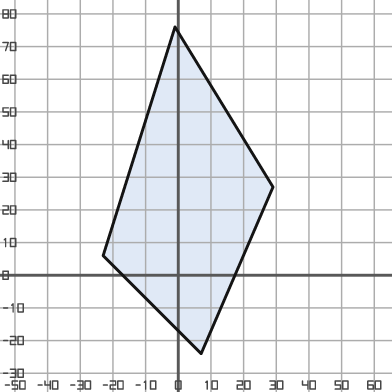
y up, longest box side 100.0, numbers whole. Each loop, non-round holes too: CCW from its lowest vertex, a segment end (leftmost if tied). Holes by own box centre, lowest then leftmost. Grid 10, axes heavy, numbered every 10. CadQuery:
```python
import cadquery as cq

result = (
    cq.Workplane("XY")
    .moveTo(7.0, -24.0)
    .lineTo(29.0, 27.0)
    .lineTo(-1.0, 76.0)
    .lineTo(-23.0, 6.0)
    .close()
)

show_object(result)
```